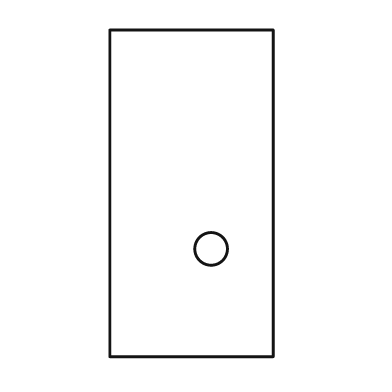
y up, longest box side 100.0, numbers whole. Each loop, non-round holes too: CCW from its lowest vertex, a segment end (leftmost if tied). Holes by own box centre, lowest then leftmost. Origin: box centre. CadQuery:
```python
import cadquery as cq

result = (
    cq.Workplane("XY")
    .moveTo(-25.0, -50.0)
    .lineTo(25.0, -50.0)
    .lineTo(25.0, 50.0)
    .lineTo(-25.0, 50.0)
    .close()
    .moveTo(6.0, -17.0)
    .circle(5.0)
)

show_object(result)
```